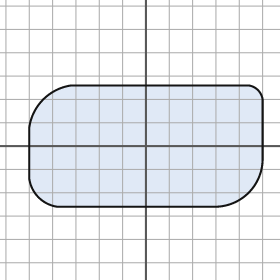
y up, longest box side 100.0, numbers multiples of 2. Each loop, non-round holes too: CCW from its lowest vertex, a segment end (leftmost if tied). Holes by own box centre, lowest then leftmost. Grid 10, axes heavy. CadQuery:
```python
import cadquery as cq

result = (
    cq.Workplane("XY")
    .moveTo(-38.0, -26.0)
    .lineTo(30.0, -26.0)
    .threePointArc((44.0, -20.0), (50.0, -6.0))
    .lineTo(50.0, 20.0)
    .threePointArc((48.0, 24.0), (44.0, 26.0))
    .lineTo(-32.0, 26.0)
    .threePointArc((-44.0, 20.0), (-50.0, 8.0))
    .lineTo(-50.0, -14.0)
    .threePointArc((-46.0, -22.0), (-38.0, -26.0))
    .close()
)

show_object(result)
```